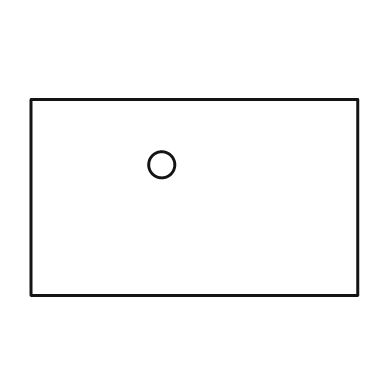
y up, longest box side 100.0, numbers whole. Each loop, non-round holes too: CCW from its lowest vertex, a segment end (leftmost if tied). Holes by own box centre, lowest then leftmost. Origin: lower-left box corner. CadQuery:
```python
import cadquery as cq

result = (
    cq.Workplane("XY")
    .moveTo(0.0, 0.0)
    .lineTo(100.0, 0.0)
    .lineTo(100.0, 60.0)
    .lineTo(0.0, 60.0)
    .close()
    .moveTo(40.0, 40.0)
    .circle(4.0)
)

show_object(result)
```